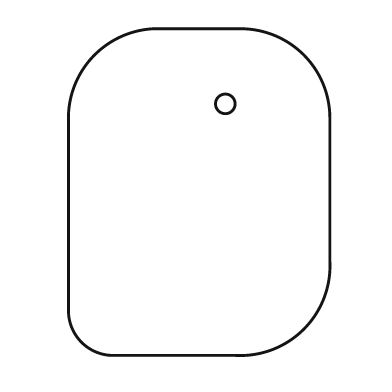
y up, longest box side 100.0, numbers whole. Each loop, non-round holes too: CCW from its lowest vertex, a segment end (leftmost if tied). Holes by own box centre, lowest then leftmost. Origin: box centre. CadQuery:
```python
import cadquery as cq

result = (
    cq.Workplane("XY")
    .moveTo(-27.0, -50.0)
    .lineTo(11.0, -50.0)
    .threePointArc((32.0, -42.0), (40.0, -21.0))
    .lineTo(40.0, 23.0)
    .threePointArc((32.0, 42.0), (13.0, 50.0))
    .lineTo(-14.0, 50.0)
    .threePointArc((-32.0, 42.0), (-40.0, 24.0))
    .lineTo(-40.0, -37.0)
    .threePointArc((-36.0, -46.0), (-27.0, -50.0))
    .close()
    .moveTo(8.0, 27.0)
    .circle(3.0)
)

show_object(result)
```